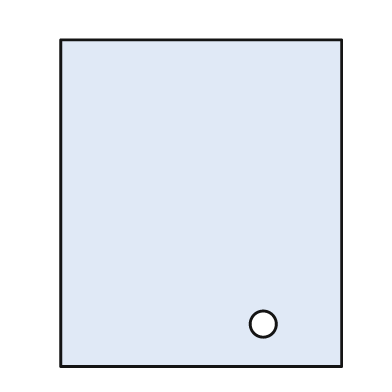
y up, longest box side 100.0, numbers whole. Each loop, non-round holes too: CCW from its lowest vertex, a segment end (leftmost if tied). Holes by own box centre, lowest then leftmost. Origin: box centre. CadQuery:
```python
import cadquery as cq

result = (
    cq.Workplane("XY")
    .moveTo(-43.0, -50.0)
    .lineTo(43.0, -50.0)
    .lineTo(43.0, 50.0)
    .lineTo(-43.0, 50.0)
    .close()
    .moveTo(19.0, -37.0)
    .circle(4.0)
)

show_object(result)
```